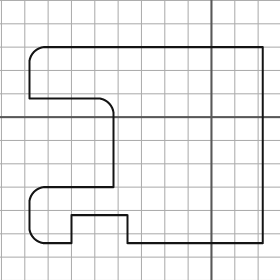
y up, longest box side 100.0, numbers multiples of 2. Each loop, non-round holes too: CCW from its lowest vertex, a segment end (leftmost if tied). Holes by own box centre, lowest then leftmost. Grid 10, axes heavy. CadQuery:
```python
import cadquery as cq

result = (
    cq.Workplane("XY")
    .moveTo(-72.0, -54.0)
    .lineTo(-60.0, -54.0)
    .lineTo(-60.0, -42.0)
    .lineTo(-36.0, -42.0)
    .lineTo(-36.0, -54.0)
    .lineTo(22.0, -54.0)
    .lineTo(22.0, 30.0)
    .lineTo(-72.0, 30.0)
    .threePointArc((-76.0, 28.0), (-78.0, 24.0))
    .lineTo(-78.0, 8.0)
    .lineTo(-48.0, 8.0)
    .threePointArc((-44.0, 6.0), (-42.0, 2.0))
    .lineTo(-42.0, -30.0)
    .lineTo(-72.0, -30.0)
    .threePointArc((-76.0, -32.0), (-78.0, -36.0))
    .lineTo(-78.0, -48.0)
    .threePointArc((-76.0, -52.0), (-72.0, -54.0))
    .close()
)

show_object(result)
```